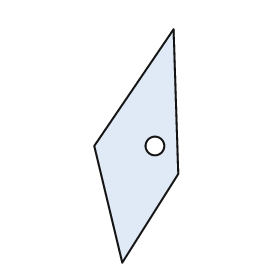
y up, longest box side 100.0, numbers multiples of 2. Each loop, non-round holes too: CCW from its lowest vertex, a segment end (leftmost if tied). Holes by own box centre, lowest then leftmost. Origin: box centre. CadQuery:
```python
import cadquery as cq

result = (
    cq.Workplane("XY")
    .moveTo(-6.0, -50.0)
    .lineTo(18.0, -12.0)
    .lineTo(16.0, 50.0)
    .lineTo(-18.0, 0.0)
    .close()
    .moveTo(8.0, 0.0)
    .circle(4.0)
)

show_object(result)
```